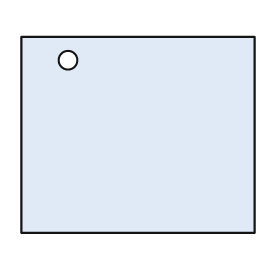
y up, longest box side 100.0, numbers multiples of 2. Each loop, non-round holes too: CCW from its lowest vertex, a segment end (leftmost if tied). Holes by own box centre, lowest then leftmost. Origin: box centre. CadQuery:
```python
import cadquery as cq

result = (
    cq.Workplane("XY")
    .moveTo(-50.0, -42.0)
    .lineTo(50.0, -42.0)
    .lineTo(50.0, 42.0)
    .lineTo(-50.0, 42.0)
    .close()
    .moveTo(-30.0, 32.0)
    .circle(4.0)
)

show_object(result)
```